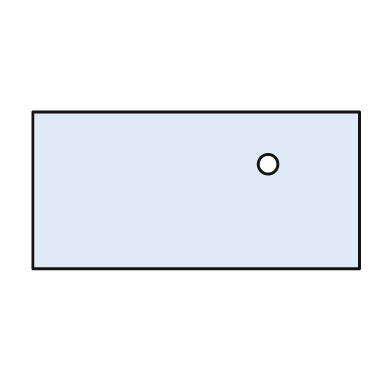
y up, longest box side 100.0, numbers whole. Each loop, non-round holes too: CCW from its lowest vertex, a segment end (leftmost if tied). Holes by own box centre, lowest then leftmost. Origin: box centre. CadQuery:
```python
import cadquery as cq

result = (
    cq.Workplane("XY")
    .moveTo(-50.0, -24.0)
    .lineTo(50.0, -24.0)
    .lineTo(50.0, 24.0)
    .lineTo(-50.0, 24.0)
    .close()
    .moveTo(22.0, 8.0)
    .circle(3.0)
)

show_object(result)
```